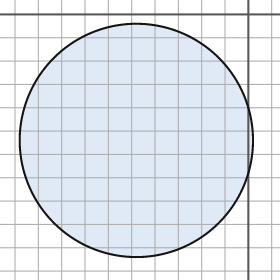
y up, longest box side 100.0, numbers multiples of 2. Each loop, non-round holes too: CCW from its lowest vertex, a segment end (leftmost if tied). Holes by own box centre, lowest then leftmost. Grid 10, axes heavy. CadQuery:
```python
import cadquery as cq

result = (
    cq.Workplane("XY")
    .moveTo(-48.0, -54.0)
    .circle(50.0)
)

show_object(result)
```